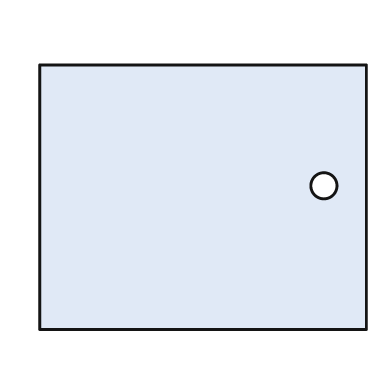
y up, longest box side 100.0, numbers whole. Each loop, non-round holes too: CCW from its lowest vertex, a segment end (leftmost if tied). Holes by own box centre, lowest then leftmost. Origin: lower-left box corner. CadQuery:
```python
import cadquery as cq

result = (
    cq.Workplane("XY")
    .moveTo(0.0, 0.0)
    .lineTo(100.0, 0.0)
    .lineTo(100.0, 81.0)
    .lineTo(0.0, 81.0)
    .close()
    .moveTo(87.0, 44.0)
    .circle(4.0)
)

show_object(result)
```